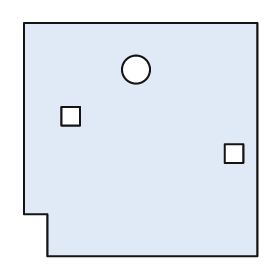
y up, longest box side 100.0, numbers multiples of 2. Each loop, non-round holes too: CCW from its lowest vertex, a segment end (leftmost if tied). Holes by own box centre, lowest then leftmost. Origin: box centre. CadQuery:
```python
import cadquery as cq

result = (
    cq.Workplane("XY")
    .moveTo(-40.0, -50.0)
    .lineTo(50.0, -50.0)
    .lineTo(50.0, 50.0)
    .lineTo(-50.0, 50.0)
    .lineTo(-50.0, -32.0)
    .lineTo(-40.0, -32.0)
    .close()
    .moveTo(36.0, -10.0)
    .lineTo(44.0, -10.0)
    .lineTo(44.0, -2.0)
    .lineTo(36.0, -2.0)
    .close()
    .moveTo(-34.0, 6.0)
    .lineTo(-26.0, 6.0)
    .lineTo(-26.0, 14.0)
    .lineTo(-34.0, 14.0)
    .close()
    .moveTo(-2.0, 30.0)
    .circle(6.0)
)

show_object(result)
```